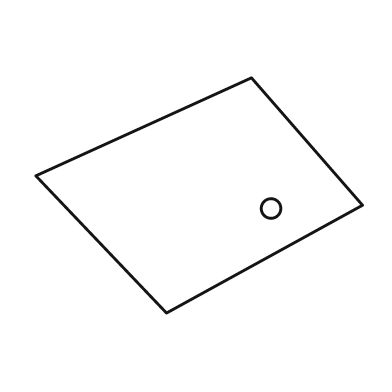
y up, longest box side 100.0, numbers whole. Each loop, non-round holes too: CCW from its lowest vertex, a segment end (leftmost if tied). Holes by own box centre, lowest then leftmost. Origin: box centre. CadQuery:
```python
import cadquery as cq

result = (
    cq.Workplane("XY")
    .moveTo(-10.0, -36.0)
    .lineTo(50.0, -3.0)
    .lineTo(16.0, 36.0)
    .lineTo(-50.0, 6.0)
    .close()
    .moveTo(22.0, -4.0)
    .circle(3.0)
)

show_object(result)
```